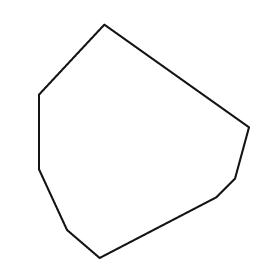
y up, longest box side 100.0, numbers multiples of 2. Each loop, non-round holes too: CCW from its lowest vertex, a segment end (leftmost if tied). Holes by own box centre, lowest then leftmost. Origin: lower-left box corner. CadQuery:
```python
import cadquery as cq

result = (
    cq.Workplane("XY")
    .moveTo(26.0, 0.0)
    .lineTo(76.0, 26.0)
    .lineTo(84.0, 34.0)
    .lineTo(90.0, 56.0)
    .lineTo(28.0, 100.0)
    .lineTo(0.0, 70.0)
    .lineTo(0.0, 38.0)
    .lineTo(12.0, 12.0)
    .close()
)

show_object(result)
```